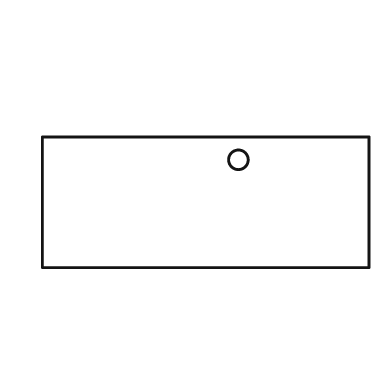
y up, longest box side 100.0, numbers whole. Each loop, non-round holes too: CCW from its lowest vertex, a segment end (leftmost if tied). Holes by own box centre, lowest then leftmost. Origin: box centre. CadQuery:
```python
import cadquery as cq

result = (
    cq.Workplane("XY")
    .moveTo(-50.0, -20.0)
    .lineTo(50.0, -20.0)
    .lineTo(50.0, 20.0)
    .lineTo(-50.0, 20.0)
    .close()
    .moveTo(10.0, 13.0)
    .circle(3.0)
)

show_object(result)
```